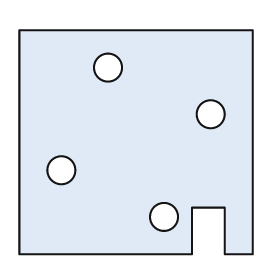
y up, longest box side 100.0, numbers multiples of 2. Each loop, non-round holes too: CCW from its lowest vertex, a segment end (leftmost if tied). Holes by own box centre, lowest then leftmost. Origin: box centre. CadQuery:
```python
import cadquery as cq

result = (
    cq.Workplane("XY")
    .moveTo(-50.0, -48.0)
    .lineTo(24.0, -48.0)
    .lineTo(24.0, -28.0)
    .lineTo(38.0, -28.0)
    .lineTo(38.0, -48.0)
    .lineTo(50.0, -48.0)
    .lineTo(50.0, 48.0)
    .lineTo(-50.0, 48.0)
    .close()
    .moveTo(12.0, -32.0)
    .circle(6.0)
    .moveTo(-32.0, -12.0)
    .circle(6.0)
    .moveTo(32.0, 12.0)
    .circle(6.0)
    .moveTo(-12.0, 32.0)
    .circle(6.0)
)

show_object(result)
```